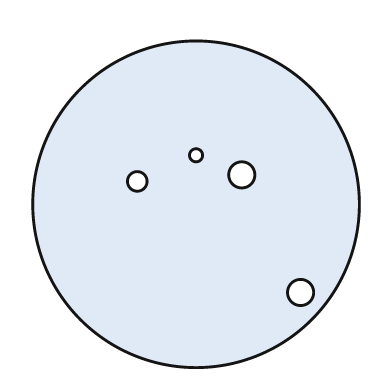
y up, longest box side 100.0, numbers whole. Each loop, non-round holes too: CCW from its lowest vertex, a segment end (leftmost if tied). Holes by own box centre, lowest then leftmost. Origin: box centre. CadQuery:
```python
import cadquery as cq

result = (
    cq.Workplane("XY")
    .moveTo(0.0, 0.0)
    .circle(50.0)
    .moveTo(32.0, -27.0)
    .circle(4.0)
    .moveTo(-18.0, 7.0)
    .circle(3.0)
    .moveTo(14.0, 9.0)
    .circle(4.0)
    .moveTo(0.0, 15.0)
    .circle(2.0)
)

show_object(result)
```